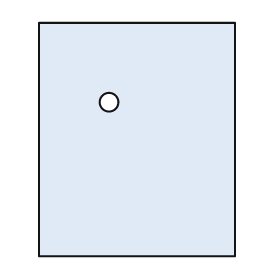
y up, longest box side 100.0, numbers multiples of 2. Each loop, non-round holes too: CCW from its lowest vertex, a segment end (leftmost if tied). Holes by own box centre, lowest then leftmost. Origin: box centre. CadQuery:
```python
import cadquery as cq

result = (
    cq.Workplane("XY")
    .moveTo(-42.0, -50.0)
    .lineTo(42.0, -50.0)
    .lineTo(42.0, 50.0)
    .lineTo(-42.0, 50.0)
    .close()
    .moveTo(-12.0, 16.0)
    .circle(4.0)
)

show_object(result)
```